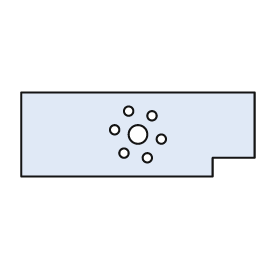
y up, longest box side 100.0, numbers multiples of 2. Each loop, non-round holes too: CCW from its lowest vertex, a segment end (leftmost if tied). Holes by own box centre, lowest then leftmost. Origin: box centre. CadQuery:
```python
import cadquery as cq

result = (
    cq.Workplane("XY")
    .moveTo(-50.0, -18.0)
    .lineTo(32.0, -18.0)
    .lineTo(32.0, -10.0)
    .lineTo(50.0, -10.0)
    .lineTo(50.0, 18.0)
    .lineTo(-50.0, 18.0)
    .close()
    .moveTo(4.0, -10.0)
    .circle(2.0)
    .moveTo(-6.0, -8.0)
    .circle(2.0)
    .moveTo(10.0, -2.0)
    .circle(2.0)
    .moveTo(0.0, 0.0)
    .circle(4.0)
    .moveTo(-10.0, 2.0)
    .circle(2.0)
    .moveTo(6.0, 8.0)
    .circle(2.0)
    .moveTo(-4.0, 10.0)
    .circle(2.0)
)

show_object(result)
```